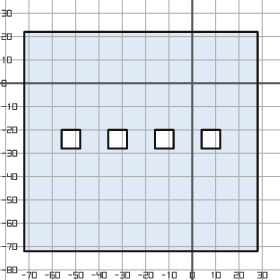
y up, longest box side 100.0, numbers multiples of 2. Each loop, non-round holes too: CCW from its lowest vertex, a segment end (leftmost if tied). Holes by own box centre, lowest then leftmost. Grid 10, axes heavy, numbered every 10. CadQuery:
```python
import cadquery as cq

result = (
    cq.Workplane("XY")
    .moveTo(-72.0, -72.0)
    .lineTo(28.0, -72.0)
    .lineTo(28.0, 22.0)
    .lineTo(-72.0, 22.0)
    .close()
    .moveTo(-56.0, -28.0)
    .lineTo(-48.0, -28.0)
    .lineTo(-48.0, -20.0)
    .lineTo(-56.0, -20.0)
    .close()
    .moveTo(-36.0, -28.0)
    .lineTo(-28.0, -28.0)
    .lineTo(-28.0, -20.0)
    .lineTo(-36.0, -20.0)
    .close()
    .moveTo(-16.0, -28.0)
    .lineTo(-8.0, -28.0)
    .lineTo(-8.0, -20.0)
    .lineTo(-16.0, -20.0)
    .close()
    .moveTo(4.0, -28.0)
    .lineTo(12.0, -28.0)
    .lineTo(12.0, -20.0)
    .lineTo(4.0, -20.0)
    .close()
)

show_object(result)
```